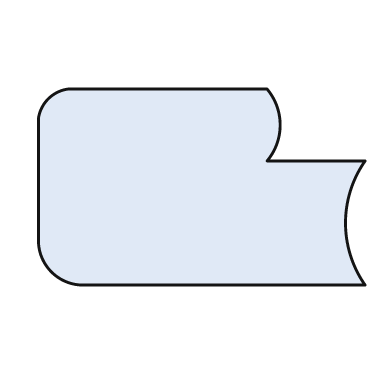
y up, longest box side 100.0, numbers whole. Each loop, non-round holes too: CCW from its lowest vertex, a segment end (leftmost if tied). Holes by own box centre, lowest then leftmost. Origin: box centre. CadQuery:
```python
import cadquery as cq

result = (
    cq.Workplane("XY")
    .moveTo(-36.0, -30.0)
    .lineTo(50.0, -30.0)
    .threePointArc((44.0, -11.0), (50.0, 8.0))
    .lineTo(20.0, 8.0)
    .threePointArc((24.0, 19.0), (20.0, 30.0))
    .lineTo(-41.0, 30.0)
    .threePointArc((-47.0, 27.0), (-50.0, 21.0))
    .lineTo(-50.0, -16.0)
    .threePointArc((-46.0, -26.0), (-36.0, -30.0))
    .close()
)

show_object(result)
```